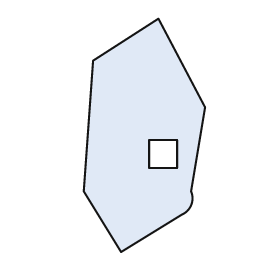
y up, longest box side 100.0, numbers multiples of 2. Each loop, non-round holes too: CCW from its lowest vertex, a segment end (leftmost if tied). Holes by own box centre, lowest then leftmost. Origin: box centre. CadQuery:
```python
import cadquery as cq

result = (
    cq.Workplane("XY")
    .moveTo(-10.0, -50.0)
    .lineTo(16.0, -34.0)
    .threePointArc((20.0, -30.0), (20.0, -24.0))
    .lineTo(26.0, 12.0)
    .lineTo(6.0, 50.0)
    .lineTo(-22.0, 32.0)
    .lineTo(-26.0, -24.0)
    .close()
    .moveTo(2.0, -14.0)
    .lineTo(14.0, -14.0)
    .lineTo(14.0, -2.0)
    .lineTo(2.0, -2.0)
    .close()
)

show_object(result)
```